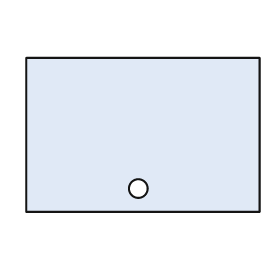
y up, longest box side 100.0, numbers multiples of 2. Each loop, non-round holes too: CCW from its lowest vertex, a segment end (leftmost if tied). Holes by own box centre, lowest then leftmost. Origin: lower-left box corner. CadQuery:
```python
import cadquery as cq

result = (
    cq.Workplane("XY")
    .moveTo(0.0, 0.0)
    .lineTo(100.0, 0.0)
    .lineTo(100.0, 66.0)
    .lineTo(0.0, 66.0)
    .close()
    .moveTo(48.0, 10.0)
    .circle(4.0)
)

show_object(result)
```